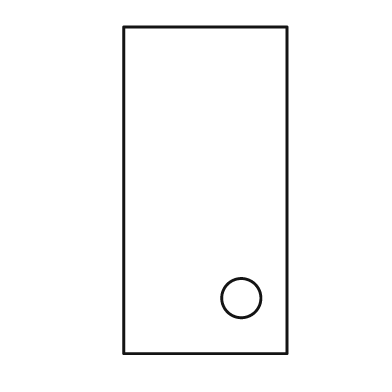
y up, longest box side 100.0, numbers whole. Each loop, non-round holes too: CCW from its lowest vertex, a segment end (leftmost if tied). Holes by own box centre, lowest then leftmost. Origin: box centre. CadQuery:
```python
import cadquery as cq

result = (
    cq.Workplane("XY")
    .moveTo(-25.0, -50.0)
    .lineTo(25.0, -50.0)
    .lineTo(25.0, 50.0)
    .lineTo(-25.0, 50.0)
    .close()
    .moveTo(11.0, -33.0)
    .circle(6.0)
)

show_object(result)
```